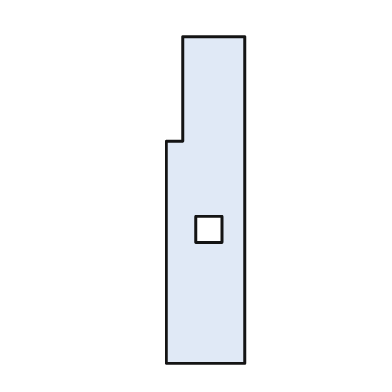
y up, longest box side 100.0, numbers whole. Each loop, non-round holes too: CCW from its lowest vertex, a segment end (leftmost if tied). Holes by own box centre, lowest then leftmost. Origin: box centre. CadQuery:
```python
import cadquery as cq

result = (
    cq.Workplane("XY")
    .moveTo(-12.0, -50.0)
    .lineTo(12.0, -50.0)
    .lineTo(12.0, 50.0)
    .lineTo(-7.0, 50.0)
    .lineTo(-7.0, 18.0)
    .lineTo(-12.0, 18.0)
    .close()
    .moveTo(-3.0, -13.0)
    .lineTo(5.0, -13.0)
    .lineTo(5.0, -5.0)
    .lineTo(-3.0, -5.0)
    .close()
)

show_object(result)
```